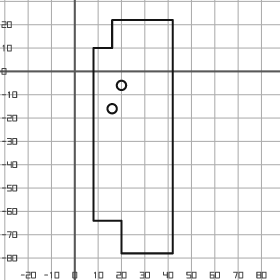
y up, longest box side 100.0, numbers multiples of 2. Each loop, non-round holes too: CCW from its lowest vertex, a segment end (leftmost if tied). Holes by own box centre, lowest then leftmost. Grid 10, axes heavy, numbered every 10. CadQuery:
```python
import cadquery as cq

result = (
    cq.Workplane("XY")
    .moveTo(20.0, -78.0)
    .lineTo(42.0, -78.0)
    .lineTo(42.0, 22.0)
    .lineTo(16.0, 22.0)
    .lineTo(16.0, 10.0)
    .lineTo(8.0, 10.0)
    .lineTo(8.0, -64.0)
    .lineTo(20.0, -64.0)
    .close()
    .moveTo(16.0, -16.0)
    .circle(2.0)
    .moveTo(20.0, -6.0)
    .circle(2.0)
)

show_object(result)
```